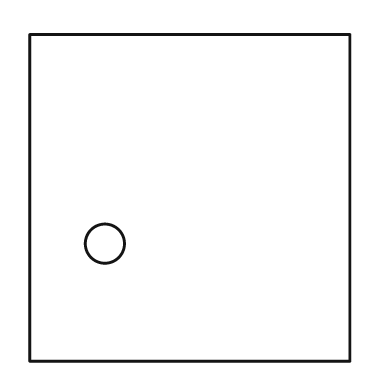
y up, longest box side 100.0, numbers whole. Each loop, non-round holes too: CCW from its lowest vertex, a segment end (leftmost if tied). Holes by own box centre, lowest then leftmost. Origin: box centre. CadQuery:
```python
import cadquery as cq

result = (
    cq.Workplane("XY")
    .moveTo(-49.0, -50.0)
    .lineTo(49.0, -50.0)
    .lineTo(49.0, 50.0)
    .lineTo(-49.0, 50.0)
    .close()
    .moveTo(-26.0, -14.0)
    .circle(6.0)
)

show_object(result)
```